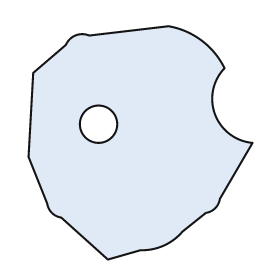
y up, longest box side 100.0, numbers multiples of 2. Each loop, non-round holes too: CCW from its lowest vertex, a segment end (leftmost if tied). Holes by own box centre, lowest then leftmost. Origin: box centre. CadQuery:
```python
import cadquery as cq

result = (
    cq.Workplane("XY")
    .moveTo(-14.0, -50.0)
    .lineTo(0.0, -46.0)
    .threePointArc((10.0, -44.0), (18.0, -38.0))
    .lineTo(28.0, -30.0)
    .threePointArc((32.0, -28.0), (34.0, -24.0))
    .lineTo(48.0, 0.0)
    .threePointArc((32.0, 12.0), (36.0, 32.0))
    .threePointArc((26.0, 44.0), (12.0, 50.0))
    .lineTo(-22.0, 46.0)
    .threePointArc((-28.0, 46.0), (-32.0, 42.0))
    .lineTo(-46.0, 30.0)
    .lineTo(-48.0, -6.0)
    .lineTo(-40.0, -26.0)
    .threePointArc((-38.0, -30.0), (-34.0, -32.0))
    .close()
    .moveTo(-18.0, 8.0)
    .circle(8.0)
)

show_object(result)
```